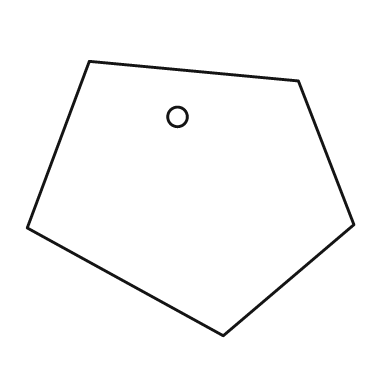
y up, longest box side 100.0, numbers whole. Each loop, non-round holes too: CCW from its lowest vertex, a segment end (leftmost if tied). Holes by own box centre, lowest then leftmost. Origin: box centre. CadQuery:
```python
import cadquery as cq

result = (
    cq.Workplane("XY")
    .moveTo(10.0, -42.0)
    .lineTo(50.0, -8.0)
    .lineTo(33.0, 36.0)
    .lineTo(-31.0, 42.0)
    .lineTo(-50.0, -9.0)
    .close()
    .moveTo(-4.0, 25.0)
    .circle(3.0)
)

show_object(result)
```